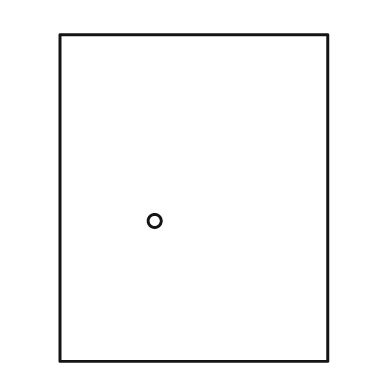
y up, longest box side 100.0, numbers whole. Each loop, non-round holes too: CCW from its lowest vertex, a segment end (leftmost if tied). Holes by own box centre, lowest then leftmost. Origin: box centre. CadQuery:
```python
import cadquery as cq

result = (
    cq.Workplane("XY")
    .moveTo(-41.0, -50.0)
    .lineTo(41.0, -50.0)
    .lineTo(41.0, 50.0)
    .lineTo(-41.0, 50.0)
    .close()
    .moveTo(-12.0, -7.0)
    .circle(2.0)
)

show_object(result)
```